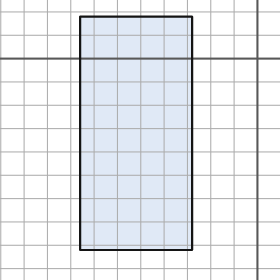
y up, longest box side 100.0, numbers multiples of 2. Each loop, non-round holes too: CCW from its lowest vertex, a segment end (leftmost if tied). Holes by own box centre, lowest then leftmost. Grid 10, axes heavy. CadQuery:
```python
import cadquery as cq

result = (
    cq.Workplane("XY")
    .moveTo(-76.0, -82.0)
    .lineTo(-28.0, -82.0)
    .lineTo(-28.0, 18.0)
    .lineTo(-76.0, 18.0)
    .close()
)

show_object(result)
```